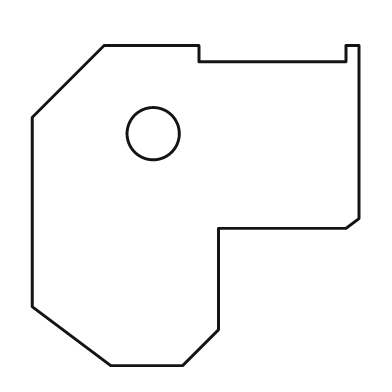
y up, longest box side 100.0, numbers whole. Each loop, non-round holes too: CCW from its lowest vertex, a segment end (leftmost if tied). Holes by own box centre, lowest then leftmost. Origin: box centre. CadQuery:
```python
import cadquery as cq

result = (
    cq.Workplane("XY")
    .moveTo(-26.0, -49.0)
    .lineTo(-4.0, -49.0)
    .lineTo(7.0, -38.0)
    .lineTo(7.0, -7.0)
    .lineTo(46.0, -7.0)
    .lineTo(50.0, -4.0)
    .lineTo(50.0, 49.0)
    .lineTo(46.0, 49.0)
    .lineTo(46.0, 44.0)
    .lineTo(1.0, 44.0)
    .lineTo(1.0, 49.0)
    .lineTo(-28.0, 49.0)
    .lineTo(-50.0, 27.0)
    .lineTo(-50.0, -31.0)
    .close()
    .moveTo(-13.0, 22.0)
    .circle(8.0)
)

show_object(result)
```